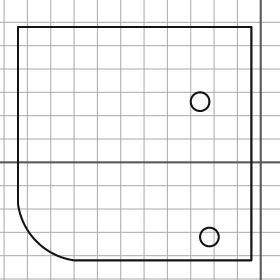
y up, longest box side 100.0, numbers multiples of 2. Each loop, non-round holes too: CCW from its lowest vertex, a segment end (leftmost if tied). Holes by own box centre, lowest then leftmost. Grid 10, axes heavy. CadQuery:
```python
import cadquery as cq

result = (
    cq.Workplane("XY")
    .moveTo(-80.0, -42.0)
    .lineTo(-4.0, -42.0)
    .lineTo(-4.0, 58.0)
    .lineTo(-104.0, 58.0)
    .lineTo(-104.0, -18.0)
    .threePointArc((-96.0, -34.0), (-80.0, -42.0))
    .close()
    .moveTo(-22.0, -32.0)
    .circle(4.0)
    .moveTo(-26.0, 26.0)
    .circle(4.0)
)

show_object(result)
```